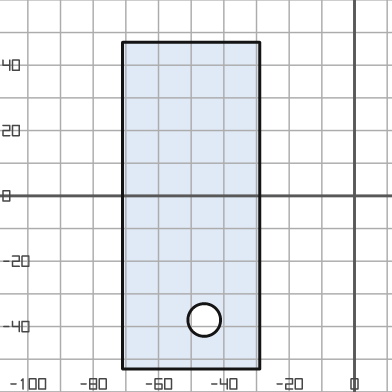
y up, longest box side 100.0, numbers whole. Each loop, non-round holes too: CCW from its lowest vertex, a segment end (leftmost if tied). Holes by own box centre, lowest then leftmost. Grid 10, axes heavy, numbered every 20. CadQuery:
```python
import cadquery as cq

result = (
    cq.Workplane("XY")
    .moveTo(-71.0, -53.0)
    .lineTo(-29.0, -53.0)
    .lineTo(-29.0, 47.0)
    .lineTo(-71.0, 47.0)
    .close()
    .moveTo(-46.0, -38.0)
    .circle(5.0)
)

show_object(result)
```